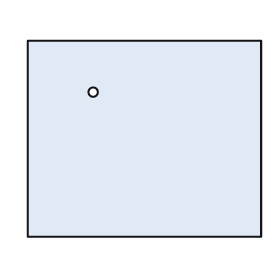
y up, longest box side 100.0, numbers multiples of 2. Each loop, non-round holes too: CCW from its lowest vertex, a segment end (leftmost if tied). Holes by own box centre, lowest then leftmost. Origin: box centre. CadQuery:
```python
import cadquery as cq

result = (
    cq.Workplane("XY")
    .moveTo(-50.0, -42.0)
    .lineTo(50.0, -42.0)
    .lineTo(50.0, 42.0)
    .lineTo(-50.0, 42.0)
    .close()
    .moveTo(-22.0, 20.0)
    .circle(2.0)
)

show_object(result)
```